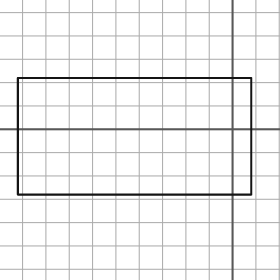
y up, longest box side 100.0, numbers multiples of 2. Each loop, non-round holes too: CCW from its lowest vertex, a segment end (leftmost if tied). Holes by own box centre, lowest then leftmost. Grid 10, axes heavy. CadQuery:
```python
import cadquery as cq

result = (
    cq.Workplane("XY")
    .moveTo(-92.0, -28.0)
    .lineTo(8.0, -28.0)
    .lineTo(8.0, 22.0)
    .lineTo(-92.0, 22.0)
    .close()
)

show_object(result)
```